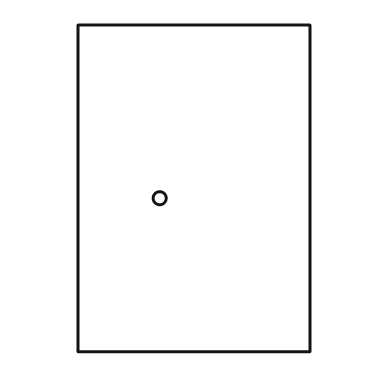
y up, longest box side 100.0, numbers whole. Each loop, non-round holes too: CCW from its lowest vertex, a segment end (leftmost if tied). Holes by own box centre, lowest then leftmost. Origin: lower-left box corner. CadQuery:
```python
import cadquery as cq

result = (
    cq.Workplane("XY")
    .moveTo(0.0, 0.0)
    .lineTo(71.0, 0.0)
    .lineTo(71.0, 100.0)
    .lineTo(0.0, 100.0)
    .close()
    .moveTo(25.0, 47.0)
    .circle(2.0)
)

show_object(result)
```